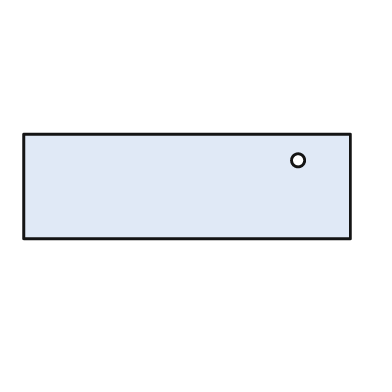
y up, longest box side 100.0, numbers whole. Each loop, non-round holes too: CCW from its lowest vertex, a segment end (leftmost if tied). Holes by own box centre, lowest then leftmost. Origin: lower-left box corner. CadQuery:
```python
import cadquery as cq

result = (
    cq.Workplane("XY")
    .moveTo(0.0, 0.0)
    .lineTo(100.0, 0.0)
    .lineTo(100.0, 32.0)
    .lineTo(0.0, 32.0)
    .close()
    .moveTo(84.0, 24.0)
    .circle(2.0)
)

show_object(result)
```